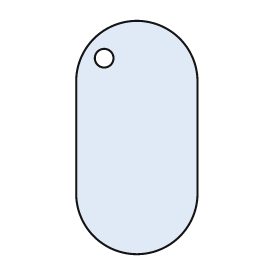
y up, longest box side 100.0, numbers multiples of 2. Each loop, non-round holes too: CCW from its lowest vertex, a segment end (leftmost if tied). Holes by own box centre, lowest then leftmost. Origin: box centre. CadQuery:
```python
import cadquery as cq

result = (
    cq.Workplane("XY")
    .moveTo(-26.0, -24.0)
    .threePointArc((0.0, -50.0), (26.0, -24.0))
    .lineTo(26.0, 24.0)
    .threePointArc((0.0, 50.0), (-26.0, 24.0))
    .close()
    .moveTo(-14.0, 34.0)
    .circle(4.0)
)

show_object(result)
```